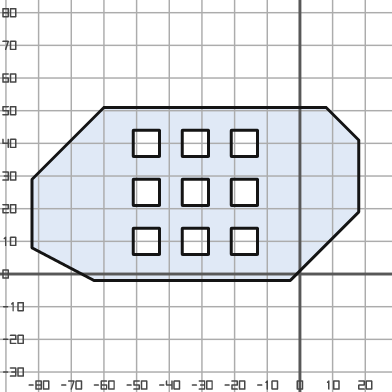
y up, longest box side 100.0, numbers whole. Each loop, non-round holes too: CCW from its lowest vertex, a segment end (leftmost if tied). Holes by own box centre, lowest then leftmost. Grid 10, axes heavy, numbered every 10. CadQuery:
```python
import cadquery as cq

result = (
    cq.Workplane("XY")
    .moveTo(-63.0, -2.0)
    .lineTo(-3.0, -2.0)
    .lineTo(18.0, 19.0)
    .lineTo(18.0, 41.0)
    .lineTo(8.0, 51.0)
    .lineTo(-60.0, 51.0)
    .lineTo(-82.0, 29.0)
    .lineTo(-82.0, 8.0)
    .close()
    .moveTo(-51.0, 6.0)
    .lineTo(-43.0, 6.0)
    .lineTo(-43.0, 14.0)
    .lineTo(-51.0, 14.0)
    .close()
    .moveTo(-36.0, 6.0)
    .lineTo(-28.0, 6.0)
    .lineTo(-28.0, 14.0)
    .lineTo(-36.0, 14.0)
    .close()
    .moveTo(-21.0, 6.0)
    .lineTo(-13.0, 6.0)
    .lineTo(-13.0, 14.0)
    .lineTo(-21.0, 14.0)
    .close()
    .moveTo(-51.0, 21.0)
    .lineTo(-43.0, 21.0)
    .lineTo(-43.0, 29.0)
    .lineTo(-51.0, 29.0)
    .close()
    .moveTo(-36.0, 21.0)
    .lineTo(-28.0, 21.0)
    .lineTo(-28.0, 29.0)
    .lineTo(-36.0, 29.0)
    .close()
    .moveTo(-21.0, 21.0)
    .lineTo(-13.0, 21.0)
    .lineTo(-13.0, 29.0)
    .lineTo(-21.0, 29.0)
    .close()
    .moveTo(-51.0, 36.0)
    .lineTo(-43.0, 36.0)
    .lineTo(-43.0, 44.0)
    .lineTo(-51.0, 44.0)
    .close()
    .moveTo(-36.0, 36.0)
    .lineTo(-28.0, 36.0)
    .lineTo(-28.0, 44.0)
    .lineTo(-36.0, 44.0)
    .close()
    .moveTo(-21.0, 36.0)
    .lineTo(-13.0, 36.0)
    .lineTo(-13.0, 44.0)
    .lineTo(-21.0, 44.0)
    .close()
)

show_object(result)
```